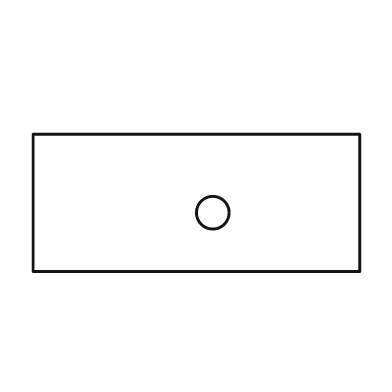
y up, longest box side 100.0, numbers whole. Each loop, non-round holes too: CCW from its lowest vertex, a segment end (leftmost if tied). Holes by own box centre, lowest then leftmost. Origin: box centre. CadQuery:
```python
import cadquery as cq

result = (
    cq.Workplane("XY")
    .moveTo(-50.0, -21.0)
    .lineTo(50.0, -21.0)
    .lineTo(50.0, 21.0)
    .lineTo(-50.0, 21.0)
    .close()
    .moveTo(5.0, -3.0)
    .circle(5.0)
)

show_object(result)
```